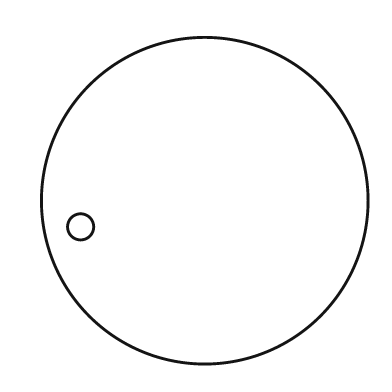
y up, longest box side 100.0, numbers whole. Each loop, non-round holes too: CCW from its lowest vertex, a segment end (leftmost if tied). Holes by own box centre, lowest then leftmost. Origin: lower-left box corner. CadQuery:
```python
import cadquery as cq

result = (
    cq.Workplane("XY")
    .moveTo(50.0, 50.0)
    .circle(50.0)
    .moveTo(12.0, 42.0)
    .circle(4.0)
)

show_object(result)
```